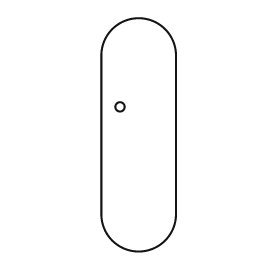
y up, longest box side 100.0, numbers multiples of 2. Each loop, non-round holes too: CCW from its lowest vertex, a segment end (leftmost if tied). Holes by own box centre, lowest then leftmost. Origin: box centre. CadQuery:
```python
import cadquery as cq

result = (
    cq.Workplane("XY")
    .moveTo(-16.0, -34.0)
    .threePointArc((0.0, -50.0), (16.0, -34.0))
    .lineTo(16.0, 34.0)
    .threePointArc((0.0, 50.0), (-16.0, 34.0))
    .close()
    .moveTo(-8.0, 12.0)
    .circle(2.0)
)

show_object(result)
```